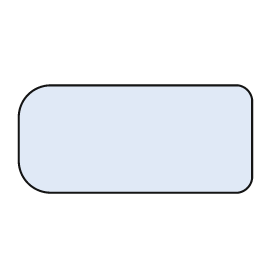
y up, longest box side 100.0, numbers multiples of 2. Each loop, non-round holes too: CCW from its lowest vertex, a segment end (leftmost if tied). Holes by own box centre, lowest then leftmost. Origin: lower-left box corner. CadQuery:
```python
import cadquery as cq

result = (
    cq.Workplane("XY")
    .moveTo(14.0, 0.0)
    .lineTo(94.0, 0.0)
    .threePointArc((98.0, 2.0), (100.0, 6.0))
    .lineTo(100.0, 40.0)
    .threePointArc((98.0, 44.0), (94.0, 46.0))
    .lineTo(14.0, 46.0)
    .threePointArc((4.0, 42.0), (0.0, 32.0))
    .lineTo(0.0, 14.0)
    .threePointArc((4.0, 4.0), (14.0, 0.0))
    .close()
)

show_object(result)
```